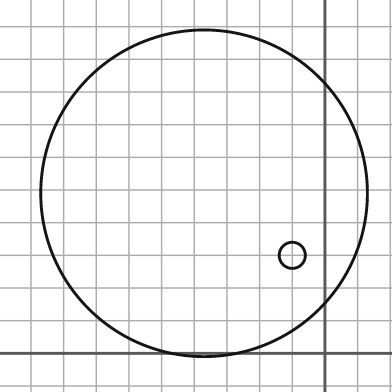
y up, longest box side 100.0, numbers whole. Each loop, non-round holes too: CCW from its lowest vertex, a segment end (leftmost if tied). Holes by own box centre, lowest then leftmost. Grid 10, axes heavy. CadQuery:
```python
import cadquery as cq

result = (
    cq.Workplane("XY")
    .moveTo(-37.0, 49.0)
    .circle(50.0)
    .moveTo(-10.0, 30.0)
    .circle(4.0)
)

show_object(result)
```